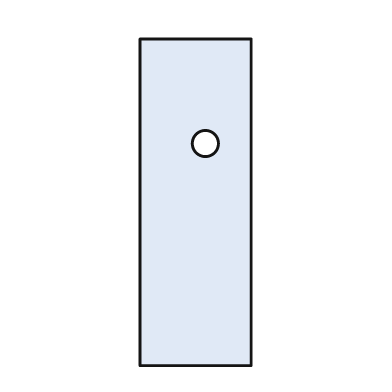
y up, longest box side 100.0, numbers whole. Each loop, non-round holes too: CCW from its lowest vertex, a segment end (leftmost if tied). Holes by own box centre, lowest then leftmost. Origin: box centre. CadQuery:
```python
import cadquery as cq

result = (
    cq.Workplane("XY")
    .moveTo(-17.0, -50.0)
    .lineTo(17.0, -50.0)
    .lineTo(17.0, 50.0)
    .lineTo(-17.0, 50.0)
    .close()
    .moveTo(3.0, 18.0)
    .circle(4.0)
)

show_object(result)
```